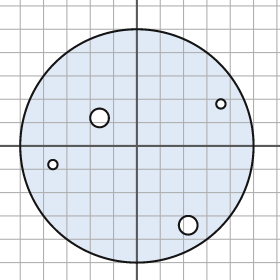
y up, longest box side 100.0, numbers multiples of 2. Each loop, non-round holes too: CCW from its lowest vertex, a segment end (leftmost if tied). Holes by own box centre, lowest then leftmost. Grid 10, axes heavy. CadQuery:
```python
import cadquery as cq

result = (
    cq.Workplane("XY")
    .moveTo(0.0, 0.0)
    .circle(50.0)
    .moveTo(22.0, -34.0)
    .circle(4.0)
    .moveTo(-36.0, -8.0)
    .circle(2.0)
    .moveTo(-16.0, 12.0)
    .circle(4.0)
    .moveTo(36.0, 18.0)
    .circle(2.0)
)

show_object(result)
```